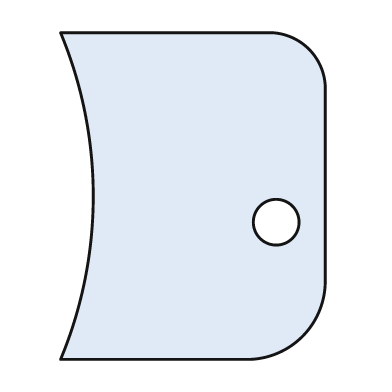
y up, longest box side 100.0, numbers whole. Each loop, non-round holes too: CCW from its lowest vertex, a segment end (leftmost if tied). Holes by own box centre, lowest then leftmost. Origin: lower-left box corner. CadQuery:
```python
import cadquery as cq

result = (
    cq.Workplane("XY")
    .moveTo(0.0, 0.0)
    .lineTo(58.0, 0.0)
    .threePointArc((74.0, 7.0), (81.0, 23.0))
    .lineTo(81.0, 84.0)
    .threePointArc((76.0, 95.0), (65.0, 100.0))
    .lineTo(0.0, 100.0)
    .threePointArc((10.0, 50.0), (0.0, 0.0))
    .close()
    .moveTo(66.0, 42.0)
    .circle(7.0)
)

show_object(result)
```